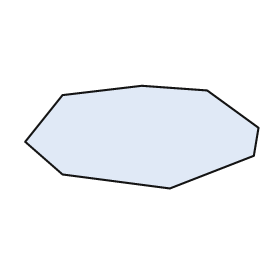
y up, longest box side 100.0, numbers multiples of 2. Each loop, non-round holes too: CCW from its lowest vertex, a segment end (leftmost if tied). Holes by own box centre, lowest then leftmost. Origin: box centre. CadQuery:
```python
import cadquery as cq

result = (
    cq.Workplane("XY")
    .moveTo(12.0, -22.0)
    .lineTo(48.0, -8.0)
    .lineTo(50.0, 4.0)
    .lineTo(28.0, 20.0)
    .lineTo(0.0, 22.0)
    .lineTo(-34.0, 18.0)
    .lineTo(-50.0, -2.0)
    .lineTo(-34.0, -16.0)
    .close()
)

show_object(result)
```